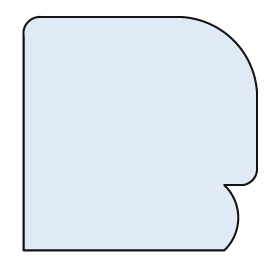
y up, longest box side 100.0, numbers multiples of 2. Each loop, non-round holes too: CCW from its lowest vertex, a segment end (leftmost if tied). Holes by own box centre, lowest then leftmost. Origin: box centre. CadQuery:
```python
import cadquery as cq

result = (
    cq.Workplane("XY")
    .moveTo(-50.0, -50.0)
    .lineTo(36.0, -50.0)
    .threePointArc((42.0, -36.0), (36.0, -22.0))
    .lineTo(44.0, -22.0)
    .threePointArc((48.0, -20.0), (50.0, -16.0))
    .lineTo(50.0, 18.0)
    .threePointArc((40.0, 40.0), (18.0, 50.0))
    .lineTo(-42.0, 50.0)
    .threePointArc((-48.0, 48.0), (-50.0, 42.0))
    .close()
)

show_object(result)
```